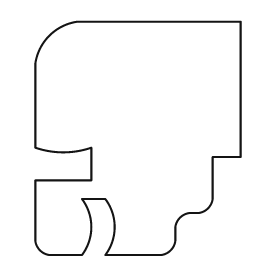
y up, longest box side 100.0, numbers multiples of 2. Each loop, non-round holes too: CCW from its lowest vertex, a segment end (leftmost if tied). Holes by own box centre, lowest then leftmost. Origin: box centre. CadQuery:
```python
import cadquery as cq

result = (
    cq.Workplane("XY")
    .moveTo(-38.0, -50.0)
    .lineTo(-24.0, -50.0)
    .threePointArc((-20.0, -38.0), (-24.0, -26.0))
    .lineTo(-14.0, -26.0)
    .threePointArc((-10.0, -38.0), (-14.0, -50.0))
    .lineTo(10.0, -50.0)
    .threePointArc((14.0, -48.0), (16.0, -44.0))
    .lineTo(16.0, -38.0)
    .threePointArc((18.0, -34.0), (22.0, -32.0))
    .lineTo(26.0, -32.0)
    .threePointArc((30.0, -30.0), (32.0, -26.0))
    .lineTo(32.0, -8.0)
    .lineTo(44.0, -8.0)
    .lineTo(44.0, 50.0)
    .lineTo(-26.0, 50.0)
    .threePointArc((-38.0, 44.0), (-44.0, 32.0))
    .lineTo(-44.0, -4.0)
    .threePointArc((-32.0, -6.0), (-20.0, -4.0))
    .lineTo(-20.0, -18.0)
    .lineTo(-44.0, -18.0)
    .lineTo(-44.0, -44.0)
    .threePointArc((-42.0, -48.0), (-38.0, -50.0))
    .close()
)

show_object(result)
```